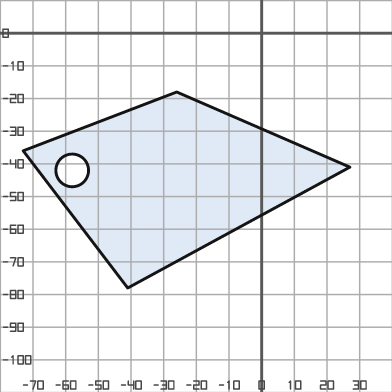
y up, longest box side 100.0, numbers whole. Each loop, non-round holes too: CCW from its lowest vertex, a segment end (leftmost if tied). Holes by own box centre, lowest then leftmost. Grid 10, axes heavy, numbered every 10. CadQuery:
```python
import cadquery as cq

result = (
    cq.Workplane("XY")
    .moveTo(-41.0, -78.0)
    .lineTo(27.0, -41.0)
    .lineTo(-26.0, -18.0)
    .lineTo(-73.0, -36.0)
    .close()
    .moveTo(-58.0, -42.0)
    .circle(5.0)
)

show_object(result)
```